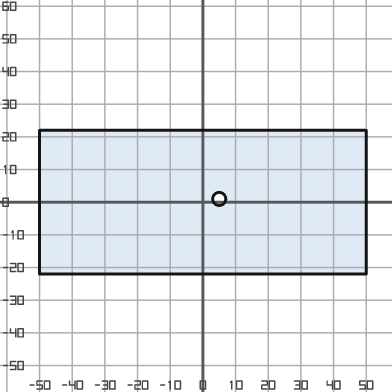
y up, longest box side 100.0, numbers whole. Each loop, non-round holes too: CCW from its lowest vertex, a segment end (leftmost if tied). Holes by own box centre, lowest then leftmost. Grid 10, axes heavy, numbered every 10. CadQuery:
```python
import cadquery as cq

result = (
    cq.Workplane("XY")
    .moveTo(-50.0, -22.0)
    .lineTo(50.0, -22.0)
    .lineTo(50.0, 22.0)
    .lineTo(-50.0, 22.0)
    .close()
    .moveTo(5.0, 1.0)
    .circle(2.0)
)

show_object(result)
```